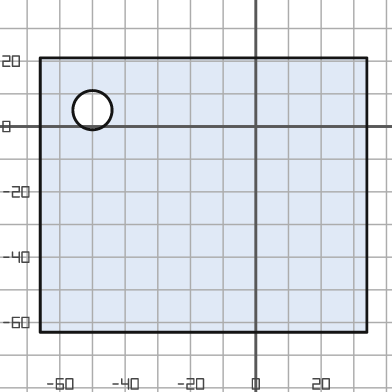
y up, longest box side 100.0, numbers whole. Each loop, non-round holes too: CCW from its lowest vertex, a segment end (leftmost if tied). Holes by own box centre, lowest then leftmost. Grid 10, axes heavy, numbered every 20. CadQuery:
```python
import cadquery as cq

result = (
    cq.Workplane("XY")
    .moveTo(-66.0, -63.0)
    .lineTo(34.0, -63.0)
    .lineTo(34.0, 21.0)
    .lineTo(-66.0, 21.0)
    .close()
    .moveTo(-50.0, 5.0)
    .circle(6.0)
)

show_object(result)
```